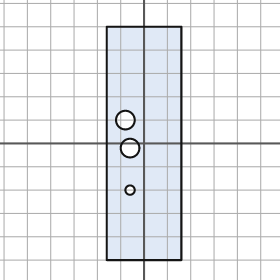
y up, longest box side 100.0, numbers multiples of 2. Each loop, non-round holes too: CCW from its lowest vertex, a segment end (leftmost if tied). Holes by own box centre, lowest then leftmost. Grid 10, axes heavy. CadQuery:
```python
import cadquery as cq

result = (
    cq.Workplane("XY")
    .moveTo(-16.0, -50.0)
    .lineTo(16.0, -50.0)
    .lineTo(16.0, 50.0)
    .lineTo(-16.0, 50.0)
    .close()
    .moveTo(-6.0, -20.0)
    .circle(2.0)
    .moveTo(-6.0, -2.0)
    .circle(4.0)
    .moveTo(-8.0, 10.0)
    .circle(4.0)
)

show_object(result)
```